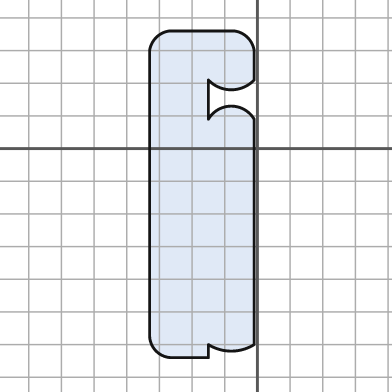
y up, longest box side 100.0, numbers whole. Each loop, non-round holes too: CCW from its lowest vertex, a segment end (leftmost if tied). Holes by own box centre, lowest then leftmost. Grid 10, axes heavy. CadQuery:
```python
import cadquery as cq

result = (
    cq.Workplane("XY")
    .moveTo(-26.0, -64.0)
    .lineTo(-15.0, -64.0)
    .lineTo(-15.0, -60.0)
    .threePointArc((-8.0, -62.0), (-1.0, -60.0))
    .lineTo(-1.0, 9.0)
    .threePointArc((-8.0, 13.0), (-15.0, 9.0))
    .lineTo(-15.0, 21.0)
    .threePointArc((-8.0, 18.0), (-1.0, 21.0))
    .lineTo(-1.0, 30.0)
    .threePointArc((-3.0, 34.0), (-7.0, 36.0))
    .lineTo(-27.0, 36.0)
    .threePointArc((-31.0, 34.0), (-33.0, 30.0))
    .lineTo(-33.0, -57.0)
    .threePointArc((-31.0, -62.0), (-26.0, -64.0))
    .close()
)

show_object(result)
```